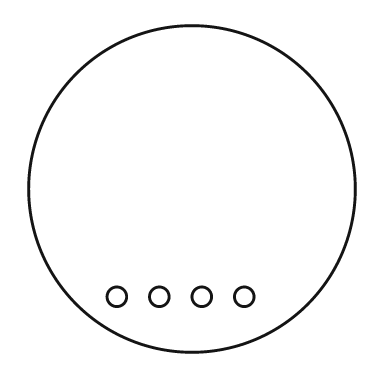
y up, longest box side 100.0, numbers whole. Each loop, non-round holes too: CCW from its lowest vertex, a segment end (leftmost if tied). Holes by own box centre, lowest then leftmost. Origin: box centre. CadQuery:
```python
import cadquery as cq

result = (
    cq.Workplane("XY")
    .moveTo(0.0, 0.0)
    .circle(50.0)
    .moveTo(-23.0, -33.0)
    .circle(3.0)
    .moveTo(-10.0, -33.0)
    .circle(3.0)
    .moveTo(3.0, -33.0)
    .circle(3.0)
    .moveTo(16.0, -33.0)
    .circle(3.0)
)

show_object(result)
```